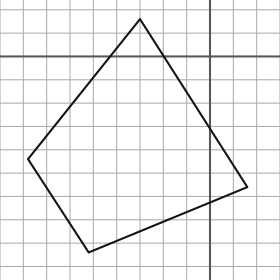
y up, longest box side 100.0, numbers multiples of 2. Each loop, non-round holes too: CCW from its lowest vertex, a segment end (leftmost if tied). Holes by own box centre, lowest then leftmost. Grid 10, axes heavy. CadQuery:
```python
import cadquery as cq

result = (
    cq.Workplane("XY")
    .moveTo(-52.0, -84.0)
    .lineTo(16.0, -56.0)
    .lineTo(-30.0, 16.0)
    .lineTo(-78.0, -44.0)
    .close()
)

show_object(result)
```